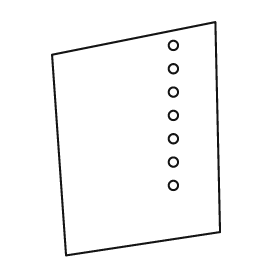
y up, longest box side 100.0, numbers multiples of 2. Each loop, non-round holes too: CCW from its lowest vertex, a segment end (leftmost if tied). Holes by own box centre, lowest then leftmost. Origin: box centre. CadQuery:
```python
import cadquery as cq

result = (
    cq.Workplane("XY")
    .moveTo(-30.0, -50.0)
    .lineTo(36.0, -40.0)
    .lineTo(34.0, 50.0)
    .lineTo(-36.0, 36.0)
    .close()
    .moveTo(16.0, -20.0)
    .circle(2.0)
    .moveTo(16.0, -10.0)
    .circle(2.0)
    .moveTo(16.0, 0.0)
    .circle(2.0)
    .moveTo(16.0, 10.0)
    .circle(2.0)
    .moveTo(16.0, 20.0)
    .circle(2.0)
    .moveTo(16.0, 30.0)
    .circle(2.0)
    .moveTo(16.0, 40.0)
    .circle(2.0)
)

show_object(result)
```